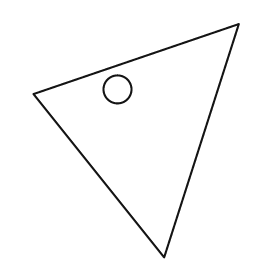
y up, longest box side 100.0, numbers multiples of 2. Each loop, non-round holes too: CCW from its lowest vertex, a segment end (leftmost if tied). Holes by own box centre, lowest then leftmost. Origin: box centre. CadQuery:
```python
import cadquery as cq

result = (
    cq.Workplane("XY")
    .moveTo(12.0, -50.0)
    .lineTo(44.0, 50.0)
    .lineTo(-44.0, 20.0)
    .close()
    .moveTo(-8.0, 22.0)
    .circle(6.0)
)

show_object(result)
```